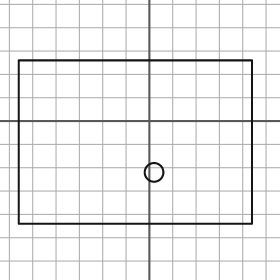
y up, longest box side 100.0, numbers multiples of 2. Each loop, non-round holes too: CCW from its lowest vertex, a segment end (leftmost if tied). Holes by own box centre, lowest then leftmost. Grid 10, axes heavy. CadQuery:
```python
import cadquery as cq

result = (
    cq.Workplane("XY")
    .moveTo(-56.0, -44.0)
    .lineTo(44.0, -44.0)
    .lineTo(44.0, 26.0)
    .lineTo(-56.0, 26.0)
    .close()
    .moveTo(2.0, -22.0)
    .circle(4.0)
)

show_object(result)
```